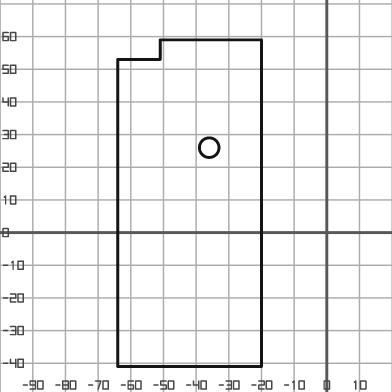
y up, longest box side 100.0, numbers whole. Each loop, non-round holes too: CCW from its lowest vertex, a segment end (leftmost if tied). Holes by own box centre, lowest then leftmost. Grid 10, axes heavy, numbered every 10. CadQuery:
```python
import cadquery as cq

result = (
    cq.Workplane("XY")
    .moveTo(-64.0, -41.0)
    .lineTo(-20.0, -41.0)
    .lineTo(-20.0, 59.0)
    .lineTo(-51.0, 59.0)
    .lineTo(-51.0, 53.0)
    .lineTo(-64.0, 53.0)
    .close()
    .moveTo(-36.0, 26.0)
    .circle(3.0)
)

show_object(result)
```